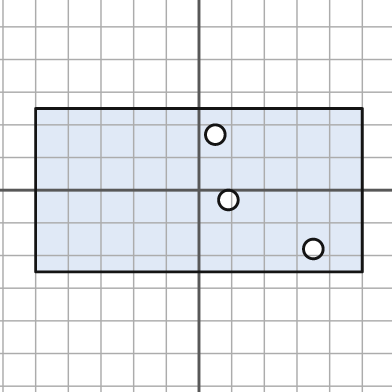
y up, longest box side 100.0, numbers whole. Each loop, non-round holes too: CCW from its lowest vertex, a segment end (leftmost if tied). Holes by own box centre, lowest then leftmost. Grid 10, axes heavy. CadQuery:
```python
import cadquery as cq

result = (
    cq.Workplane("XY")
    .moveTo(-50.0, -25.0)
    .lineTo(50.0, -25.0)
    .lineTo(50.0, 25.0)
    .lineTo(-50.0, 25.0)
    .close()
    .moveTo(35.0, -18.0)
    .circle(3.0)
    .moveTo(9.0, -3.0)
    .circle(3.0)
    .moveTo(5.0, 17.0)
    .circle(3.0)
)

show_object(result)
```